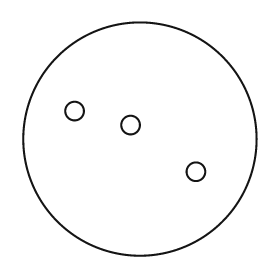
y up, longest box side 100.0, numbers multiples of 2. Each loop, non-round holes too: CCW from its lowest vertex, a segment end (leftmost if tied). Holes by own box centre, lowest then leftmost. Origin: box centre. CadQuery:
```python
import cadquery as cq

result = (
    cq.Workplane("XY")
    .moveTo(0.0, 0.0)
    .circle(50.0)
    .moveTo(24.0, -14.0)
    .circle(4.0)
    .moveTo(-4.0, 6.0)
    .circle(4.0)
    .moveTo(-28.0, 12.0)
    .circle(4.0)
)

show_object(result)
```